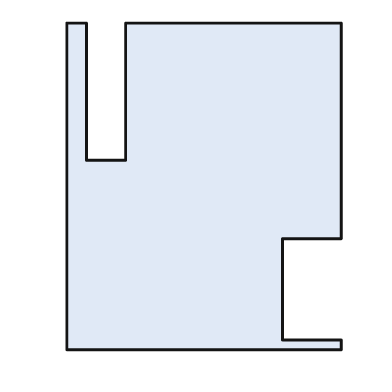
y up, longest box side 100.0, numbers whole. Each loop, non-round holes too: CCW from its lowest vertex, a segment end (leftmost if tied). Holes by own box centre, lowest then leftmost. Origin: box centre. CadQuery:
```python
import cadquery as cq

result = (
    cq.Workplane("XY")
    .moveTo(-42.0, -50.0)
    .lineTo(42.0, -50.0)
    .lineTo(42.0, -47.0)
    .lineTo(24.0, -47.0)
    .lineTo(24.0, -16.0)
    .lineTo(42.0, -16.0)
    .lineTo(42.0, 50.0)
    .lineTo(-24.0, 50.0)
    .lineTo(-24.0, 8.0)
    .lineTo(-36.0, 8.0)
    .lineTo(-36.0, 50.0)
    .lineTo(-42.0, 50.0)
    .close()
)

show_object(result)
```